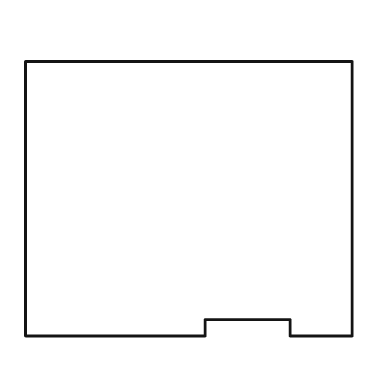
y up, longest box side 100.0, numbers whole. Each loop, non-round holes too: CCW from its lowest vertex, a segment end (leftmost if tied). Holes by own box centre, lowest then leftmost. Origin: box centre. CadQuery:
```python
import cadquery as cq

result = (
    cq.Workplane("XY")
    .moveTo(-50.0, -42.0)
    .lineTo(5.0, -42.0)
    .lineTo(5.0, -37.0)
    .lineTo(31.0, -37.0)
    .lineTo(31.0, -42.0)
    .lineTo(50.0, -42.0)
    .lineTo(50.0, 42.0)
    .lineTo(-50.0, 42.0)
    .close()
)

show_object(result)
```